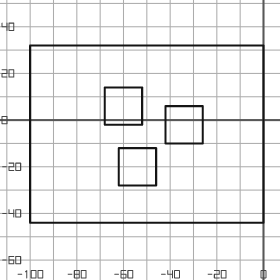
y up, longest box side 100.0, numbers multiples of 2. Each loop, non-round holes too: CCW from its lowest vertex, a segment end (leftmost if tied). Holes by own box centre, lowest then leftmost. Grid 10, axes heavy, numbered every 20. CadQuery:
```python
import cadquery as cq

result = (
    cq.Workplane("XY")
    .moveTo(-100.0, -44.0)
    .lineTo(0.0, -44.0)
    .lineTo(0.0, 32.0)
    .lineTo(-100.0, 32.0)
    .close()
    .moveTo(-62.0, -28.0)
    .lineTo(-46.0, -28.0)
    .lineTo(-46.0, -12.0)
    .lineTo(-62.0, -12.0)
    .close()
    .moveTo(-42.0, -10.0)
    .lineTo(-26.0, -10.0)
    .lineTo(-26.0, 6.0)
    .lineTo(-42.0, 6.0)
    .close()
    .moveTo(-68.0, -2.0)
    .lineTo(-52.0, -2.0)
    .lineTo(-52.0, 14.0)
    .lineTo(-68.0, 14.0)
    .close()
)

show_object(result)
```